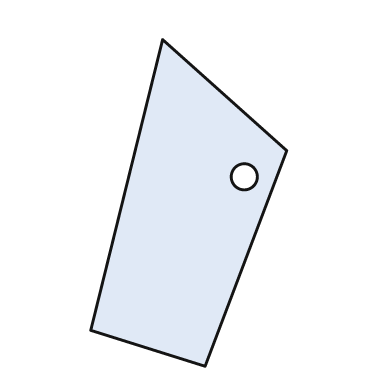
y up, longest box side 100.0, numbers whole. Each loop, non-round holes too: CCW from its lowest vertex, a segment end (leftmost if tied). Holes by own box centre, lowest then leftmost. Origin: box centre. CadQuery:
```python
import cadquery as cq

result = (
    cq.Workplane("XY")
    .moveTo(5.0, -50.0)
    .lineTo(30.0, 16.0)
    .lineTo(-8.0, 50.0)
    .lineTo(-30.0, -39.0)
    .close()
    .moveTo(17.0, 8.0)
    .circle(4.0)
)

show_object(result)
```